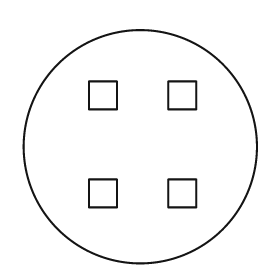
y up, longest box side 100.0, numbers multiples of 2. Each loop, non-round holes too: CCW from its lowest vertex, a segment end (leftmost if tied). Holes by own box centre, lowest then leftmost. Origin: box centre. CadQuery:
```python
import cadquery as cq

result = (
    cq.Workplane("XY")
    .moveTo(0.0, 0.0)
    .circle(50.0)
    .moveTo(-22.0, -26.0)
    .lineTo(-10.0, -26.0)
    .lineTo(-10.0, -14.0)
    .lineTo(-22.0, -14.0)
    .close()
    .moveTo(12.0, -26.0)
    .lineTo(24.0, -26.0)
    .lineTo(24.0, -14.0)
    .lineTo(12.0, -14.0)
    .close()
    .moveTo(-22.0, 16.0)
    .lineTo(-10.0, 16.0)
    .lineTo(-10.0, 28.0)
    .lineTo(-22.0, 28.0)
    .close()
    .moveTo(12.0, 16.0)
    .lineTo(24.0, 16.0)
    .lineTo(24.0, 28.0)
    .lineTo(12.0, 28.0)
    .close()
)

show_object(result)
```